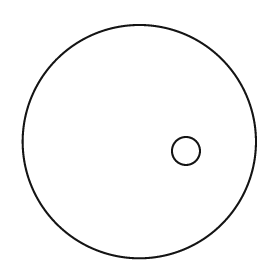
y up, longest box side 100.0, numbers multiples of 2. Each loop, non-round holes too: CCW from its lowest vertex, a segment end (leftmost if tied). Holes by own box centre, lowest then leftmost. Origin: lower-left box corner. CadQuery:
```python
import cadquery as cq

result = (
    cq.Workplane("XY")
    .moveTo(50.0, 50.0)
    .circle(50.0)
    .moveTo(70.0, 46.0)
    .circle(6.0)
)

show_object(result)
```